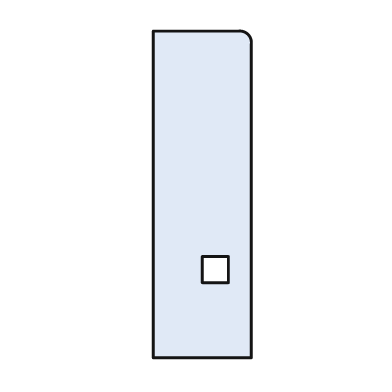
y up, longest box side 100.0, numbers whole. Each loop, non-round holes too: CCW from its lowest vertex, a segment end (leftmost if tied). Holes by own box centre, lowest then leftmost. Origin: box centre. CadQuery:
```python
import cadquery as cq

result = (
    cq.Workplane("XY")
    .moveTo(-15.0, -50.0)
    .lineTo(15.0, -50.0)
    .lineTo(15.0, 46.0)
    .threePointArc((14.0, 49.0), (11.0, 50.0))
    .lineTo(-15.0, 50.0)
    .close()
    .moveTo(0.0, -27.0)
    .lineTo(8.0, -27.0)
    .lineTo(8.0, -19.0)
    .lineTo(0.0, -19.0)
    .close()
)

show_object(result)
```